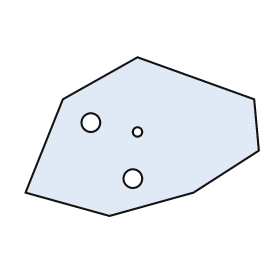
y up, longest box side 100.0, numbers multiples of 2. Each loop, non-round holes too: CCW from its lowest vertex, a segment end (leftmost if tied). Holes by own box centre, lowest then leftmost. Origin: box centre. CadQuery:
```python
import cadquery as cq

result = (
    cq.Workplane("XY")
    .moveTo(-14.0, -34.0)
    .lineTo(22.0, -24.0)
    .lineTo(50.0, -6.0)
    .lineTo(48.0, 16.0)
    .lineTo(-2.0, 34.0)
    .lineTo(-34.0, 16.0)
    .lineTo(-50.0, -24.0)
    .close()
    .moveTo(-4.0, -18.0)
    .circle(4.0)
    .moveTo(-2.0, 2.0)
    .circle(2.0)
    .moveTo(-22.0, 6.0)
    .circle(4.0)
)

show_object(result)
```